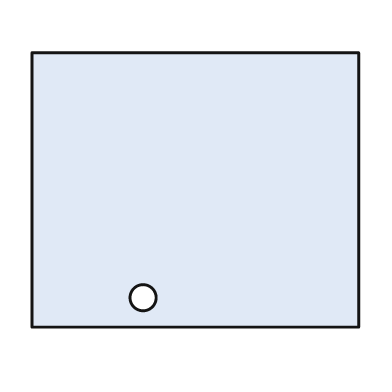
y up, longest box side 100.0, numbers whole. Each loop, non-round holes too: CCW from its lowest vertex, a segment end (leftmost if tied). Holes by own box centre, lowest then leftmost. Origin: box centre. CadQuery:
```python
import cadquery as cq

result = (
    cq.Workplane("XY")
    .moveTo(-50.0, -42.0)
    .lineTo(50.0, -42.0)
    .lineTo(50.0, 42.0)
    .lineTo(-50.0, 42.0)
    .close()
    .moveTo(-16.0, -33.0)
    .circle(4.0)
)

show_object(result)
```